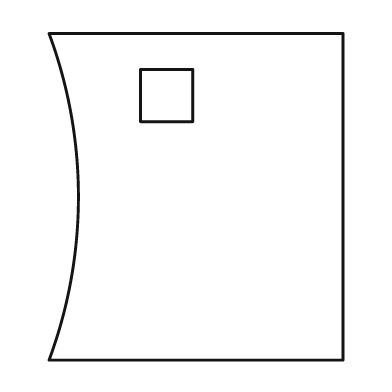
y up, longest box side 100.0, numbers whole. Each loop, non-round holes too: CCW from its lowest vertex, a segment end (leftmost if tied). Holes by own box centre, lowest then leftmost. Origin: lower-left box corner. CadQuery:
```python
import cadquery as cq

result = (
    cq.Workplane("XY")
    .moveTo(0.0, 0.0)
    .lineTo(90.0, 0.0)
    .lineTo(90.0, 100.0)
    .lineTo(0.0, 100.0)
    .threePointArc((9.0, 50.0), (0.0, 0.0))
    .close()
    .moveTo(28.0, 73.0)
    .lineTo(44.0, 73.0)
    .lineTo(44.0, 89.0)
    .lineTo(28.0, 89.0)
    .close()
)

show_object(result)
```